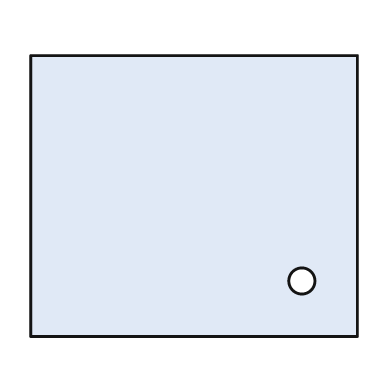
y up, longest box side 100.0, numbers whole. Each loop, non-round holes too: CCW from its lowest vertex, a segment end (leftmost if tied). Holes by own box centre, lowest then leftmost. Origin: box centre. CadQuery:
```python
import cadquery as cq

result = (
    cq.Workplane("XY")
    .moveTo(-50.0, -43.0)
    .lineTo(50.0, -43.0)
    .lineTo(50.0, 43.0)
    .lineTo(-50.0, 43.0)
    .close()
    .moveTo(33.0, -26.0)
    .circle(4.0)
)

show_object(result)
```